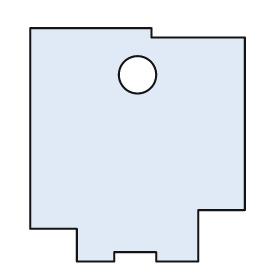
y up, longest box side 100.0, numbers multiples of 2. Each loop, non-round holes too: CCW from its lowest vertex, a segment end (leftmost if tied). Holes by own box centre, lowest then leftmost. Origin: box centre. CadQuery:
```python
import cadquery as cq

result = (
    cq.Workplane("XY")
    .moveTo(-26.0, -50.0)
    .lineTo(-10.0, -50.0)
    .lineTo(-10.0, -46.0)
    .lineTo(8.0, -46.0)
    .lineTo(8.0, -50.0)
    .lineTo(26.0, -50.0)
    .lineTo(26.0, -28.0)
    .lineTo(46.0, -28.0)
    .lineTo(46.0, 46.0)
    .lineTo(6.0, 46.0)
    .lineTo(6.0, 50.0)
    .lineTo(-46.0, 50.0)
    .lineTo(-46.0, -36.0)
    .lineTo(-26.0, -36.0)
    .close()
    .moveTo(0.0, 30.0)
    .circle(8.0)
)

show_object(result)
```